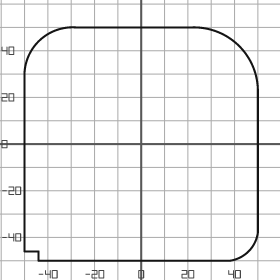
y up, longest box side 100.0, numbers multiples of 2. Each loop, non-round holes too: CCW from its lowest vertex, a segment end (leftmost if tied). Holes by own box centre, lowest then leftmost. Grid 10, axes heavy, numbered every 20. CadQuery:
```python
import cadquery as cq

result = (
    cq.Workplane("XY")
    .moveTo(-44.0, -50.0)
    .lineTo(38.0, -50.0)
    .threePointArc((46.0, -46.0), (50.0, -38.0))
    .lineTo(50.0, 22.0)
    .threePointArc((42.0, 42.0), (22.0, 50.0))
    .lineTo(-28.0, 50.0)
    .threePointArc((-44.0, 44.0), (-50.0, 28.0))
    .lineTo(-50.0, -46.0)
    .lineTo(-44.0, -46.0)
    .close()
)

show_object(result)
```